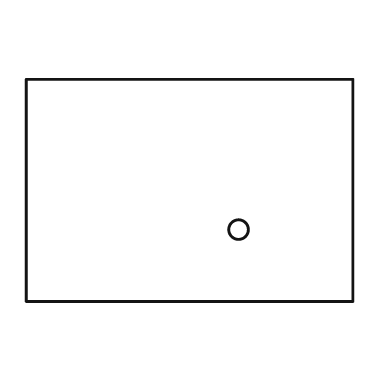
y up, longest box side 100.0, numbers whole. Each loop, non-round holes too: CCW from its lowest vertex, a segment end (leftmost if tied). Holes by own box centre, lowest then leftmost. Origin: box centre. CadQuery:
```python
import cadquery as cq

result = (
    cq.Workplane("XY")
    .moveTo(-50.0, -34.0)
    .lineTo(50.0, -34.0)
    .lineTo(50.0, 34.0)
    .lineTo(-50.0, 34.0)
    .close()
    .moveTo(15.0, -12.0)
    .circle(3.0)
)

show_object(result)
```